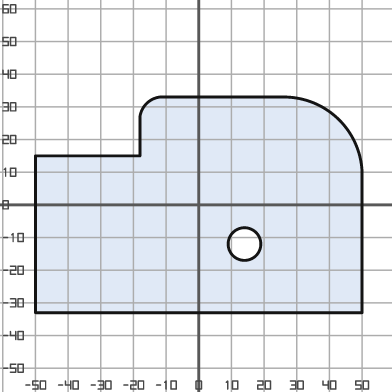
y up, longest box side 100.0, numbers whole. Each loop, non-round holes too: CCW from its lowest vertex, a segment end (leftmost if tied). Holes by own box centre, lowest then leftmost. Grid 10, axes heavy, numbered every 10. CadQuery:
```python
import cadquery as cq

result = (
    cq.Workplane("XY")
    .moveTo(-50.0, -33.0)
    .lineTo(50.0, -33.0)
    .lineTo(50.0, 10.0)
    .threePointArc((43.0, 26.0), (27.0, 33.0))
    .lineTo(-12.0, 33.0)
    .threePointArc((-16.0, 31.0), (-18.0, 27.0))
    .lineTo(-18.0, 15.0)
    .lineTo(-50.0, 15.0)
    .close()
    .moveTo(14.0, -12.0)
    .circle(5.0)
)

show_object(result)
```